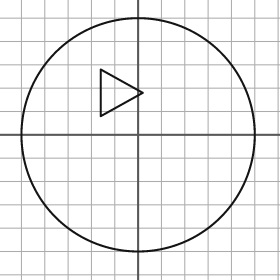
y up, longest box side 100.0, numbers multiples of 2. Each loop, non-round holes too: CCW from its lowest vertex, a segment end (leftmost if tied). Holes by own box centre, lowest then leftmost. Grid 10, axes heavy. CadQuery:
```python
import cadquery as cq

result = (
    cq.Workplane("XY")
    .moveTo(0.0, 0.0)
    .circle(50.0)
    .moveTo(-16.0, 8.0)
    .lineTo(2.0, 18.0)
    .lineTo(-16.0, 28.0)
    .close()
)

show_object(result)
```